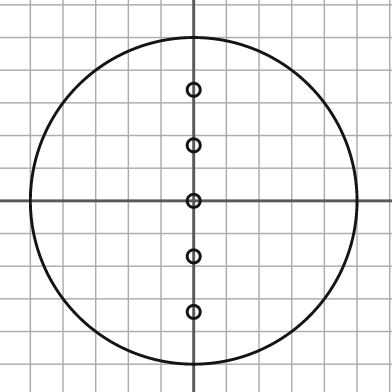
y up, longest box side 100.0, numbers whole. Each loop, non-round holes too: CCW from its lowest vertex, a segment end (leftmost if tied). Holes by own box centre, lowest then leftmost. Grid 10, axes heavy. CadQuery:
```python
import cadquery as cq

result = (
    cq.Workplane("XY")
    .moveTo(0.0, 0.0)
    .circle(50.0)
    .moveTo(0.0, -34.0)
    .circle(2.0)
    .moveTo(0.0, -17.0)
    .circle(2.0)
    .moveTo(0.0, 0.0)
    .circle(2.0)
    .moveTo(0.0, 17.0)
    .circle(2.0)
    .moveTo(0.0, 34.0)
    .circle(2.0)
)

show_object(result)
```